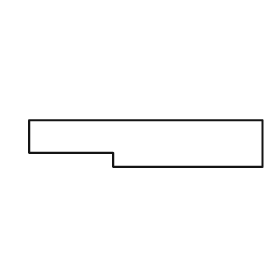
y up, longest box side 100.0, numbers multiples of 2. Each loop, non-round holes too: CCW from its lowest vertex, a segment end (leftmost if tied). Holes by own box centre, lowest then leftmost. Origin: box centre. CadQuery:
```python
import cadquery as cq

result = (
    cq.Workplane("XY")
    .moveTo(-14.0, -10.0)
    .lineTo(50.0, -10.0)
    .lineTo(50.0, 10.0)
    .lineTo(-50.0, 10.0)
    .lineTo(-50.0, -4.0)
    .lineTo(-14.0, -4.0)
    .close()
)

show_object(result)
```